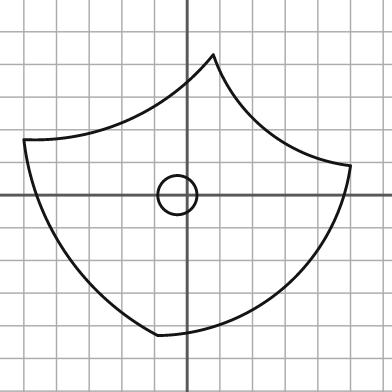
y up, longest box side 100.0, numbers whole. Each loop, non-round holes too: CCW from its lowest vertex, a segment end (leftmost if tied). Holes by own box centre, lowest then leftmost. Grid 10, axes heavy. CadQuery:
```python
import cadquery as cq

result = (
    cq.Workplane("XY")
    .moveTo(-9.0, -43.0)
    .threePointArc((30.0, -28.0), (50.0, 9.0))
    .threePointArc((24.0, 20.0), (8.0, 43.0))
    .threePointArc((-18.0, 23.0), (-50.0, 17.0))
    .threePointArc((-37.0, -18.0), (-9.0, -43.0))
    .close()
    .moveTo(-3.0, 0.0)
    .circle(6.0)
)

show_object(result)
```